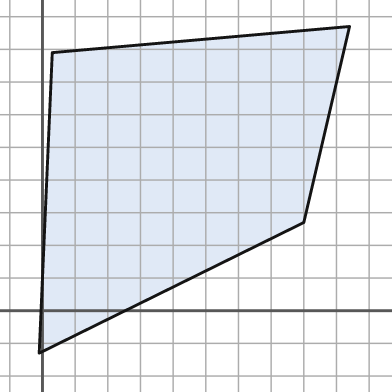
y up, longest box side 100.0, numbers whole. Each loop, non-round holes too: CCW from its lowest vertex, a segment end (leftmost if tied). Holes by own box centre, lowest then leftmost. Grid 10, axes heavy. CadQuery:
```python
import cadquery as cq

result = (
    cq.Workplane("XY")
    .moveTo(-1.0, -13.0)
    .lineTo(80.0, 27.0)
    .lineTo(94.0, 87.0)
    .lineTo(3.0, 79.0)
    .close()
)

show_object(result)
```